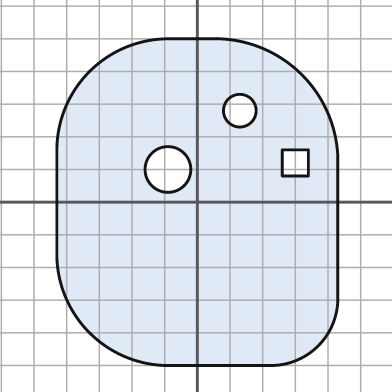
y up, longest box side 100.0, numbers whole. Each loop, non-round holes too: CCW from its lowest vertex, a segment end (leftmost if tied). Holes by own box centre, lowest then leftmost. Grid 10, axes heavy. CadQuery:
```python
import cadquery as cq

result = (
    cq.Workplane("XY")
    .moveTo(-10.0, -50.0)
    .lineTo(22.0, -50.0)
    .threePointArc((37.0, -44.0), (43.0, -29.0))
    .lineTo(43.0, 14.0)
    .threePointArc((32.0, 39.0), (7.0, 50.0))
    .lineTo(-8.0, 50.0)
    .threePointArc((-33.0, 40.0), (-43.0, 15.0))
    .lineTo(-43.0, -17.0)
    .threePointArc((-33.0, -40.0), (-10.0, -50.0))
    .close()
    .moveTo(-9.0, 10.0)
    .circle(7.0)
    .moveTo(26.0, 8.0)
    .lineTo(34.0, 8.0)
    .lineTo(34.0, 16.0)
    .lineTo(26.0, 16.0)
    .close()
    .moveTo(13.0, 28.0)
    .circle(5.0)
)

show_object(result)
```